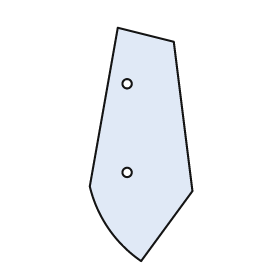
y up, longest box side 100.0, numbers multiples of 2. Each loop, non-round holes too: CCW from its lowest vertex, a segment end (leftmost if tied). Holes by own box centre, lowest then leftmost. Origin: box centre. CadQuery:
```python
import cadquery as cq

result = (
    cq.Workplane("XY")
    .moveTo(0.0, -50.0)
    .lineTo(22.0, -20.0)
    .lineTo(14.0, 44.0)
    .lineTo(-10.0, 50.0)
    .lineTo(-22.0, -18.0)
    .threePointArc((-14.0, -36.0), (0.0, -50.0))
    .close()
    .moveTo(-6.0, -12.0)
    .circle(2.0)
    .moveTo(-6.0, 26.0)
    .circle(2.0)
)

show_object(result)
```